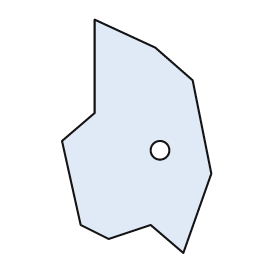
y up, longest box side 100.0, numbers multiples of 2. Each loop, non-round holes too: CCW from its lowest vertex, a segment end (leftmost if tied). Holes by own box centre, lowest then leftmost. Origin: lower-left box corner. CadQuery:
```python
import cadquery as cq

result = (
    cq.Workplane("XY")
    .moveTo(52.0, 0.0)
    .lineTo(64.0, 34.0)
    .lineTo(56.0, 74.0)
    .lineTo(40.0, 88.0)
    .lineTo(14.0, 100.0)
    .lineTo(14.0, 60.0)
    .lineTo(0.0, 48.0)
    .lineTo(8.0, 12.0)
    .lineTo(20.0, 6.0)
    .lineTo(38.0, 12.0)
    .close()
    .moveTo(42.0, 44.0)
    .circle(4.0)
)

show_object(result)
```